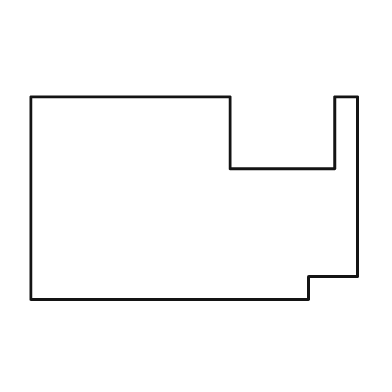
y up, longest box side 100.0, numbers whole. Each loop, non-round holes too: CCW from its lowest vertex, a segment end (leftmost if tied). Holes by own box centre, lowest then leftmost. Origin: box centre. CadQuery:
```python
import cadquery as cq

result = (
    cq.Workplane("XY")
    .moveTo(-50.0, -31.0)
    .lineTo(35.0, -31.0)
    .lineTo(35.0, -24.0)
    .lineTo(50.0, -24.0)
    .lineTo(50.0, 31.0)
    .lineTo(43.0, 31.0)
    .lineTo(43.0, 9.0)
    .lineTo(11.0, 9.0)
    .lineTo(11.0, 31.0)
    .lineTo(-50.0, 31.0)
    .close()
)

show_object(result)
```